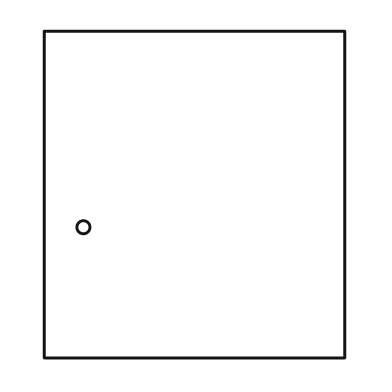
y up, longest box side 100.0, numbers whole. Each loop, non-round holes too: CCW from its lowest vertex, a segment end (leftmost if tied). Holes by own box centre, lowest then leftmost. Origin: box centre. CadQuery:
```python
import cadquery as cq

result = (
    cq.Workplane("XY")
    .moveTo(-46.0, -50.0)
    .lineTo(46.0, -50.0)
    .lineTo(46.0, 50.0)
    .lineTo(-46.0, 50.0)
    .close()
    .moveTo(-34.0, -10.0)
    .circle(2.0)
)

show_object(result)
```